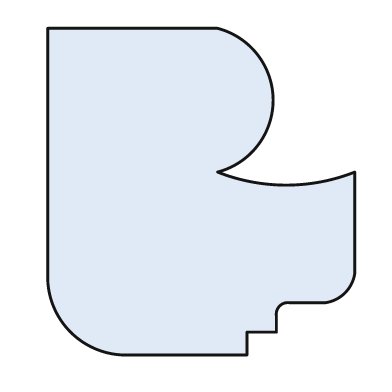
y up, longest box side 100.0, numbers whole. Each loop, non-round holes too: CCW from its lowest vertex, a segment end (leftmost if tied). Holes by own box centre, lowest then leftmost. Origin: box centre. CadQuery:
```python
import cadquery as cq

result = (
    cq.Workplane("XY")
    .moveTo(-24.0, -50.0)
    .lineTo(14.0, -50.0)
    .lineTo(14.0, -43.0)
    .lineTo(23.0, -43.0)
    .lineTo(23.0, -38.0)
    .threePointArc((24.0, -35.0), (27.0, -34.0))
    .lineTo(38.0, -34.0)
    .threePointArc((44.0, -31.0), (47.0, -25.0))
    .lineTo(47.0, 6.0)
    .threePointArc((26.0, 2.0), (5.0, 6.0))
    .threePointArc((22.0, 28.0), (5.0, 50.0))
    .lineTo(-47.0, 50.0)
    .lineTo(-47.0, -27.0)
    .threePointArc((-40.0, -43.0), (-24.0, -50.0))
    .close()
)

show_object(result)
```